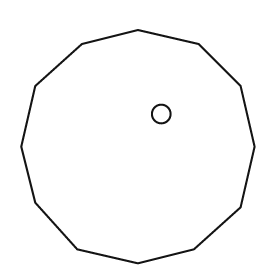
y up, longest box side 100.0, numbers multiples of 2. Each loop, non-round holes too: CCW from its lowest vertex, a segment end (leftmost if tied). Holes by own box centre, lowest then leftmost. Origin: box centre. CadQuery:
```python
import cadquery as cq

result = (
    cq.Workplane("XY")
    .moveTo(0.0, -50.0)
    .lineTo(24.0, -44.0)
    .lineTo(44.0, -26.0)
    .lineTo(50.0, 0.0)
    .lineTo(44.0, 26.0)
    .lineTo(26.0, 44.0)
    .lineTo(0.0, 50.0)
    .lineTo(-24.0, 44.0)
    .lineTo(-44.0, 26.0)
    .lineTo(-50.0, 0.0)
    .lineTo(-44.0, -24.0)
    .lineTo(-26.0, -44.0)
    .close()
    .moveTo(10.0, 14.0)
    .circle(4.0)
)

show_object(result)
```